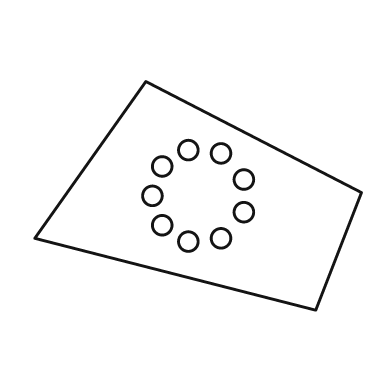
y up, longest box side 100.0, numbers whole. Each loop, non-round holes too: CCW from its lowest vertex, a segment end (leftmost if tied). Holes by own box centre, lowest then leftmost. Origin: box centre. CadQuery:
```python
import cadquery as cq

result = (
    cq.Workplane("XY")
    .moveTo(36.0, -35.0)
    .lineTo(50.0, 1.0)
    .lineTo(-16.0, 35.0)
    .lineTo(-50.0, -13.0)
    .close()
    .moveTo(-3.0, -14.0)
    .circle(3.0)
    .moveTo(7.0, -13.0)
    .circle(3.0)
    .moveTo(-11.0, -9.0)
    .circle(3.0)
    .moveTo(14.0, -5.0)
    .circle(3.0)
    .moveTo(-14.0, 0.0)
    .circle(3.0)
    .moveTo(14.0, 5.0)
    .circle(3.0)
    .moveTo(-11.0, 9.0)
    .circle(3.0)
    .moveTo(7.0, 13.0)
    .circle(3.0)
    .moveTo(-3.0, 14.0)
    .circle(3.0)
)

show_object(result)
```